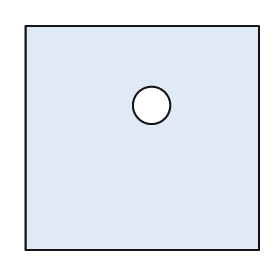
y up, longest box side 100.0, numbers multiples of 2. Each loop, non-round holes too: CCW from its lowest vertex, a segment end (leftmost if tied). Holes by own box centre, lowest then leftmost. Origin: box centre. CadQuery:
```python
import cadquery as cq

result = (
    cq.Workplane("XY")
    .moveTo(-50.0, -48.0)
    .lineTo(50.0, -48.0)
    .lineTo(50.0, 48.0)
    .lineTo(-50.0, 48.0)
    .close()
    .moveTo(4.0, 14.0)
    .circle(8.0)
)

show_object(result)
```